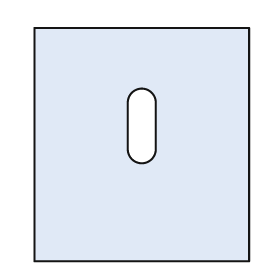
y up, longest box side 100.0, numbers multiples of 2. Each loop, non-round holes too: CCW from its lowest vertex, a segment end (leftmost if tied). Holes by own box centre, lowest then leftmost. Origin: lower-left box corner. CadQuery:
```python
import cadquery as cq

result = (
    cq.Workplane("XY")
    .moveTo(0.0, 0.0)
    .lineTo(92.0, 0.0)
    .lineTo(92.0, 100.0)
    .lineTo(0.0, 100.0)
    .close()
    .moveTo(40.0, 48.0)
    .threePointArc((46.0, 42.0), (52.0, 48.0))
    .lineTo(52.0, 68.0)
    .threePointArc((46.0, 74.0), (40.0, 68.0))
    .close()
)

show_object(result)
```